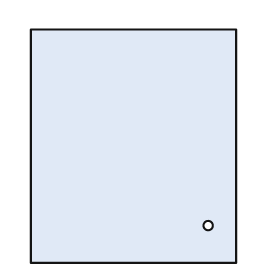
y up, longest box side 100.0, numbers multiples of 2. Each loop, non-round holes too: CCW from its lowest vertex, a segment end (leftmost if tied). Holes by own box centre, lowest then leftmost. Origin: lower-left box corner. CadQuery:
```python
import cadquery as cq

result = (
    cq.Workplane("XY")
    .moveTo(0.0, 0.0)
    .lineTo(88.0, 0.0)
    .lineTo(88.0, 100.0)
    .lineTo(0.0, 100.0)
    .close()
    .moveTo(76.0, 16.0)
    .circle(2.0)
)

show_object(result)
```